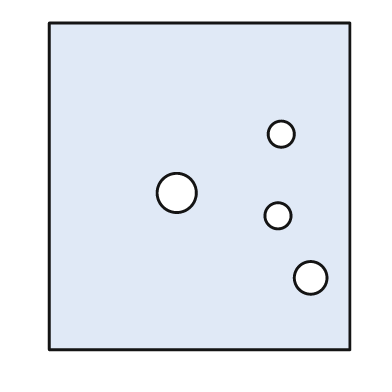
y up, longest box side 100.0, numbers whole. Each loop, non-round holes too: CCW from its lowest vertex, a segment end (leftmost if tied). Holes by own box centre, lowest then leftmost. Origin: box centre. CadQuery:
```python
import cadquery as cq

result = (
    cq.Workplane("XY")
    .moveTo(-46.0, -50.0)
    .lineTo(46.0, -50.0)
    .lineTo(46.0, 50.0)
    .lineTo(-46.0, 50.0)
    .close()
    .moveTo(34.0, -28.0)
    .circle(5.0)
    .moveTo(24.0, -9.0)
    .circle(4.0)
    .moveTo(-7.0, -2.0)
    .circle(6.0)
    .moveTo(25.0, 16.0)
    .circle(4.0)
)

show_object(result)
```